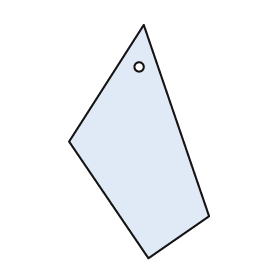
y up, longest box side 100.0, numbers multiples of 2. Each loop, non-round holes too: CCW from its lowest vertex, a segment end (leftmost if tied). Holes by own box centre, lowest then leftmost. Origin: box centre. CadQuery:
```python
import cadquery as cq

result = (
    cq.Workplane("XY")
    .moveTo(4.0, -50.0)
    .lineTo(30.0, -32.0)
    .lineTo(2.0, 50.0)
    .lineTo(-30.0, 0.0)
    .close()
    .moveTo(0.0, 32.0)
    .circle(2.0)
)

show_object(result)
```